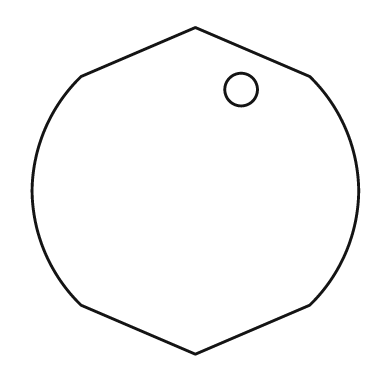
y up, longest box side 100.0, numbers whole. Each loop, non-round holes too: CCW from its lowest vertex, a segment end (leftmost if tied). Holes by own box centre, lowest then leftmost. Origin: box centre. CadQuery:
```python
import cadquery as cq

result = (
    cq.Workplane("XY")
    .moveTo(0.0, -50.0)
    .lineTo(35.0, -35.0)
    .threePointArc((46.0, -19.0), (50.0, 0.0))
    .threePointArc((46.0, 19.0), (35.0, 35.0))
    .lineTo(0.0, 50.0)
    .lineTo(-35.0, 35.0)
    .threePointArc((-46.0, 19.0), (-50.0, 0.0))
    .threePointArc((-46.0, -19.0), (-35.0, -35.0))
    .close()
    .moveTo(14.0, 31.0)
    .circle(5.0)
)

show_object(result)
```